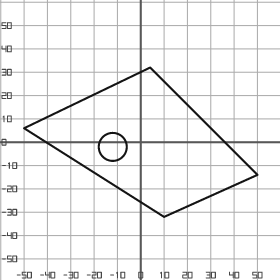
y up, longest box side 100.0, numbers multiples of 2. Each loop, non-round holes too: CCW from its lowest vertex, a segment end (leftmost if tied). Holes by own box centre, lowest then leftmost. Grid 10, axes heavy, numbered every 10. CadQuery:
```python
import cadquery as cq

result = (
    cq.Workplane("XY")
    .moveTo(10.0, -32.0)
    .lineTo(50.0, -14.0)
    .lineTo(4.0, 32.0)
    .lineTo(-50.0, 6.0)
    .close()
    .moveTo(-12.0, -2.0)
    .circle(6.0)
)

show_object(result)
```